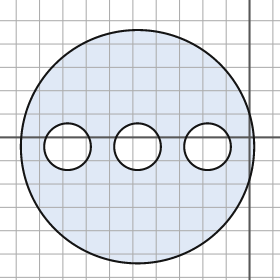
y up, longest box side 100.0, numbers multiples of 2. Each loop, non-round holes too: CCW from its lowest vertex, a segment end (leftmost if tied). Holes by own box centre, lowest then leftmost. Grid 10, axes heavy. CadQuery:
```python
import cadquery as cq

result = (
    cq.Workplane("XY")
    .moveTo(-48.0, -4.0)
    .circle(50.0)
    .moveTo(-78.0, -4.0)
    .circle(10.0)
    .moveTo(-48.0, -4.0)
    .circle(10.0)
    .moveTo(-18.0, -4.0)
    .circle(10.0)
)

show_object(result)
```